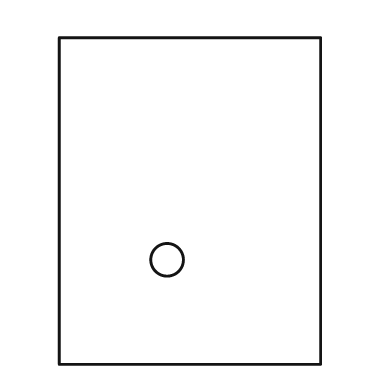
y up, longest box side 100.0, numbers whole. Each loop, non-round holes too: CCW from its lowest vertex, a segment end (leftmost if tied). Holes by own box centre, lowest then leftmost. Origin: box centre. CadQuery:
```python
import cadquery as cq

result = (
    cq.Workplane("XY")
    .moveTo(-40.0, -50.0)
    .lineTo(40.0, -50.0)
    .lineTo(40.0, 50.0)
    .lineTo(-40.0, 50.0)
    .close()
    .moveTo(-7.0, -18.0)
    .circle(5.0)
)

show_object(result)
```